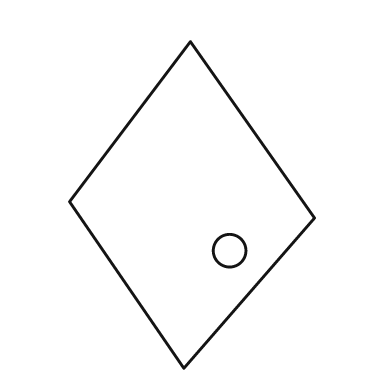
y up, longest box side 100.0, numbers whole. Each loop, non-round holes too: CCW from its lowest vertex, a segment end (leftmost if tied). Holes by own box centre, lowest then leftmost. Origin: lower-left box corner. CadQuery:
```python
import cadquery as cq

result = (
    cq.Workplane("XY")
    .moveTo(35.0, 0.0)
    .lineTo(75.0, 46.0)
    .lineTo(37.0, 100.0)
    .lineTo(0.0, 51.0)
    .close()
    .moveTo(49.0, 36.0)
    .circle(5.0)
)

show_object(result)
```